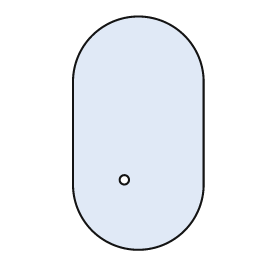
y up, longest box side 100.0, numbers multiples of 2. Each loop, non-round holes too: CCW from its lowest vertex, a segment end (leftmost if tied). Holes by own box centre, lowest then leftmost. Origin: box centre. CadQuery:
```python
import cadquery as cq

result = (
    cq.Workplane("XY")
    .moveTo(-28.0, -22.0)
    .threePointArc((0.0, -50.0), (28.0, -22.0))
    .lineTo(28.0, 22.0)
    .threePointArc((0.0, 50.0), (-28.0, 22.0))
    .close()
    .moveTo(-6.0, -20.0)
    .circle(2.0)
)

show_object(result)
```